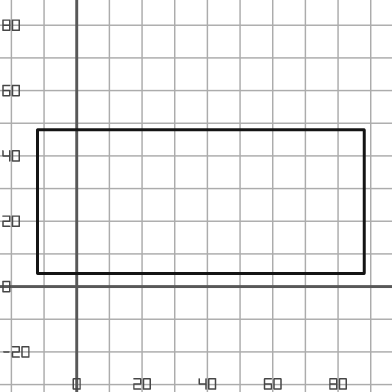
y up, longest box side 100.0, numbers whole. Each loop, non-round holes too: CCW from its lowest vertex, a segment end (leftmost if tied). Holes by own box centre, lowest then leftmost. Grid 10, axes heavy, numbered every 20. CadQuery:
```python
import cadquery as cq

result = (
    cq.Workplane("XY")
    .moveTo(-12.0, 4.0)
    .lineTo(88.0, 4.0)
    .lineTo(88.0, 48.0)
    .lineTo(-12.0, 48.0)
    .close()
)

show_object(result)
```